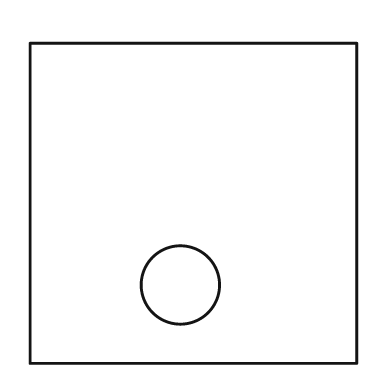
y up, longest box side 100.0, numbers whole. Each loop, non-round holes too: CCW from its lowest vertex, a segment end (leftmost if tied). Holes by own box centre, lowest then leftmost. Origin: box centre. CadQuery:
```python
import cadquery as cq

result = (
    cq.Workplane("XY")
    .moveTo(-50.0, -49.0)
    .lineTo(50.0, -49.0)
    .lineTo(50.0, 49.0)
    .lineTo(-50.0, 49.0)
    .close()
    .moveTo(-4.0, -25.0)
    .circle(12.0)
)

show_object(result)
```